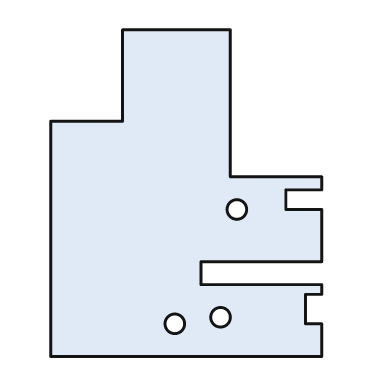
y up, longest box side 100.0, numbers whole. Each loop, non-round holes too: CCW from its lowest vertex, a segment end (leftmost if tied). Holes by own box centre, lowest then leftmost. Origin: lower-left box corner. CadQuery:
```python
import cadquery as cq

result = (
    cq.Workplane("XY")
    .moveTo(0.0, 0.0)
    .lineTo(83.0, 0.0)
    .lineTo(83.0, 10.0)
    .lineTo(78.0, 10.0)
    .lineTo(78.0, 19.0)
    .lineTo(83.0, 19.0)
    .lineTo(83.0, 22.0)
    .lineTo(46.0, 22.0)
    .lineTo(46.0, 29.0)
    .lineTo(83.0, 29.0)
    .lineTo(83.0, 45.0)
    .lineTo(72.0, 45.0)
    .lineTo(72.0, 51.0)
    .lineTo(83.0, 51.0)
    .lineTo(83.0, 55.0)
    .lineTo(55.0, 55.0)
    .lineTo(55.0, 100.0)
    .lineTo(22.0, 100.0)
    .lineTo(22.0, 72.0)
    .lineTo(0.0, 72.0)
    .close()
    .moveTo(38.0, 10.0)
    .circle(3.0)
    .moveTo(52.0, 12.0)
    .circle(3.0)
    .moveTo(57.0, 45.0)
    .circle(3.0)
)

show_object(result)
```